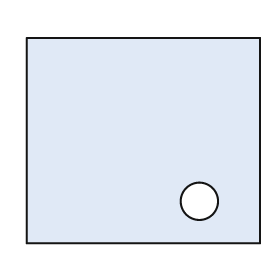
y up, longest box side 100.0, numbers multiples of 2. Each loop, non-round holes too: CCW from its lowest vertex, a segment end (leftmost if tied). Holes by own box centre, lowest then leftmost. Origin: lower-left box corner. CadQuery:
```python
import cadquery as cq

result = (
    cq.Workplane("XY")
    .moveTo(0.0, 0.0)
    .lineTo(100.0, 0.0)
    .lineTo(100.0, 88.0)
    .lineTo(0.0, 88.0)
    .close()
    .moveTo(74.0, 18.0)
    .circle(8.0)
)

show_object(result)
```